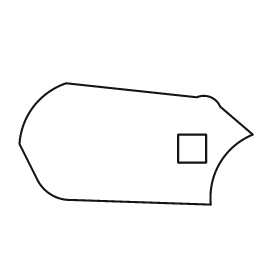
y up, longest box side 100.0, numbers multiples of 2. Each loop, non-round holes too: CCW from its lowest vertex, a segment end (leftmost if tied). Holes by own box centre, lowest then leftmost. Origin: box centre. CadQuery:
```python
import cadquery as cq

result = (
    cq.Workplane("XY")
    .moveTo(32.0, -26.0)
    .threePointArc((36.0, -8.0), (50.0, 4.0))
    .lineTo(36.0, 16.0)
    .threePointArc((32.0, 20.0), (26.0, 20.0))
    .lineTo(-30.0, 26.0)
    .threePointArc((-44.0, 16.0), (-50.0, 0.0))
    .lineTo(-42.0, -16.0)
    .threePointArc((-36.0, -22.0), (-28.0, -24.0))
    .close()
    .moveTo(18.0, -8.0)
    .lineTo(30.0, -8.0)
    .lineTo(30.0, 4.0)
    .lineTo(18.0, 4.0)
    .close()
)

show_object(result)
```